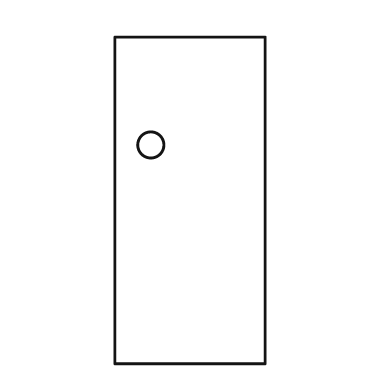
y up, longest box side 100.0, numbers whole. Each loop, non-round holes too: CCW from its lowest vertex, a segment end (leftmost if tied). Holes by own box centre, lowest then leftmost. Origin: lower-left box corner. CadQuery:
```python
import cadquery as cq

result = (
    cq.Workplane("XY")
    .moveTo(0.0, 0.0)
    .lineTo(46.0, 0.0)
    .lineTo(46.0, 100.0)
    .lineTo(0.0, 100.0)
    .close()
    .moveTo(11.0, 67.0)
    .circle(4.0)
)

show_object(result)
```